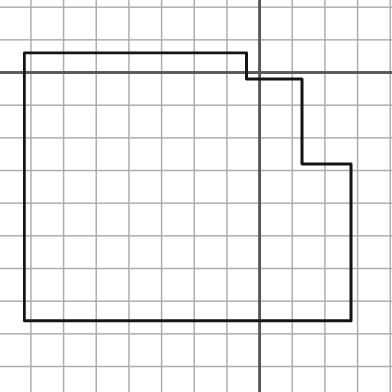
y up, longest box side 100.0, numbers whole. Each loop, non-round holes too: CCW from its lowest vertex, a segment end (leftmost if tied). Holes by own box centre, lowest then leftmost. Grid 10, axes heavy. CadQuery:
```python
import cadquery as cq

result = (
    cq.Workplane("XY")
    .moveTo(-72.0, -76.0)
    .lineTo(28.0, -76.0)
    .lineTo(28.0, -28.0)
    .lineTo(13.0, -28.0)
    .lineTo(13.0, -2.0)
    .lineTo(-4.0, -2.0)
    .lineTo(-4.0, 6.0)
    .lineTo(-72.0, 6.0)
    .close()
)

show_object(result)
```